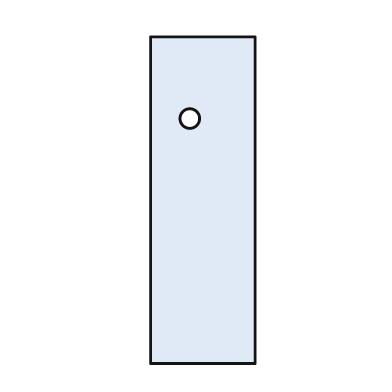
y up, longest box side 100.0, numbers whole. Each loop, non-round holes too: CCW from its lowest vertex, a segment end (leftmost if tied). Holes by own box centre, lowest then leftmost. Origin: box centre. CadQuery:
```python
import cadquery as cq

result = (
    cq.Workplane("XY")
    .moveTo(-16.0, -50.0)
    .lineTo(16.0, -50.0)
    .lineTo(16.0, 50.0)
    .lineTo(-16.0, 50.0)
    .close()
    .moveTo(-4.0, 25.0)
    .circle(3.0)
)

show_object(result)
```